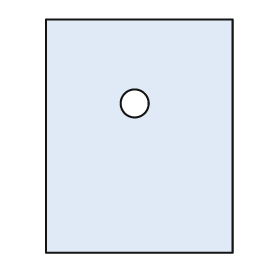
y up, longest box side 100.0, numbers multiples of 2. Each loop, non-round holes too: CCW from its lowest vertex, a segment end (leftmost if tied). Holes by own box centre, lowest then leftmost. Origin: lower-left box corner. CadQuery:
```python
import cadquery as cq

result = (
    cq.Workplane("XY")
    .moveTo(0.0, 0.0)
    .lineTo(80.0, 0.0)
    .lineTo(80.0, 100.0)
    .lineTo(0.0, 100.0)
    .close()
    .moveTo(38.0, 64.0)
    .circle(6.0)
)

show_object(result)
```